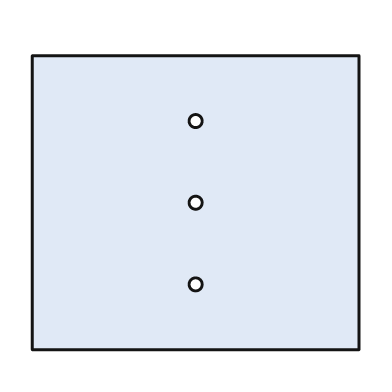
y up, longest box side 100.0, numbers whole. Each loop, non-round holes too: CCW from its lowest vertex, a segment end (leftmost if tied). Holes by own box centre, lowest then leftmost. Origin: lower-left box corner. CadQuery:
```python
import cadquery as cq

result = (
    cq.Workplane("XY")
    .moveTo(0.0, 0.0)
    .lineTo(100.0, 0.0)
    .lineTo(100.0, 90.0)
    .lineTo(0.0, 90.0)
    .close()
    .moveTo(50.0, 20.0)
    .circle(2.0)
    .moveTo(50.0, 45.0)
    .circle(2.0)
    .moveTo(50.0, 70.0)
    .circle(2.0)
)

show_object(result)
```